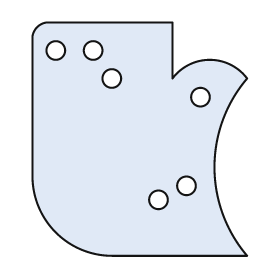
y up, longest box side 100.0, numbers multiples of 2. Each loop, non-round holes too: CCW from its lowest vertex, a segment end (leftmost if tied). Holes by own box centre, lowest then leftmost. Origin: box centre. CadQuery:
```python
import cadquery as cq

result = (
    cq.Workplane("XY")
    .moveTo(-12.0, -50.0)
    .lineTo(46.0, -50.0)
    .threePointArc((32.0, -12.0), (46.0, 26.0))
    .threePointArc((30.0, 34.0), (14.0, 26.0))
    .lineTo(14.0, 50.0)
    .lineTo(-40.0, 50.0)
    .threePointArc((-44.0, 48.0), (-46.0, 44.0))
    .lineTo(-46.0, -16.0)
    .threePointArc((-36.0, -40.0), (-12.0, -50.0))
    .close()
    .moveTo(8.0, -26.0)
    .circle(4.0)
    .moveTo(20.0, -20.0)
    .circle(4.0)
    .moveTo(26.0, 18.0)
    .circle(4.0)
    .moveTo(-12.0, 26.0)
    .circle(4.0)
    .moveTo(-36.0, 38.0)
    .circle(4.0)
    .moveTo(-20.0, 38.0)
    .circle(4.0)
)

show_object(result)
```